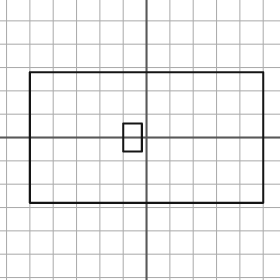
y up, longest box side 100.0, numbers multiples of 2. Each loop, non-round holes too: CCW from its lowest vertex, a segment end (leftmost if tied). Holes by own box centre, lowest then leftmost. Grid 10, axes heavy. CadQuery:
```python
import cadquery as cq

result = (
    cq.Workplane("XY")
    .moveTo(-50.0, -28.0)
    .lineTo(50.0, -28.0)
    .lineTo(50.0, 28.0)
    .lineTo(-50.0, 28.0)
    .close()
    .moveTo(-10.0, -6.0)
    .lineTo(-2.0, -6.0)
    .lineTo(-2.0, 6.0)
    .lineTo(-10.0, 6.0)
    .close()
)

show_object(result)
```